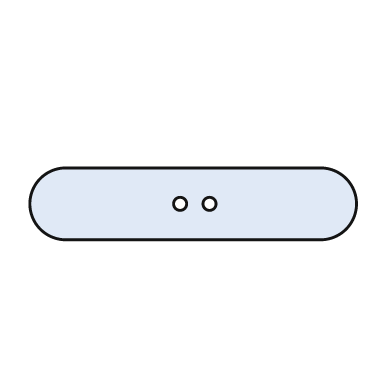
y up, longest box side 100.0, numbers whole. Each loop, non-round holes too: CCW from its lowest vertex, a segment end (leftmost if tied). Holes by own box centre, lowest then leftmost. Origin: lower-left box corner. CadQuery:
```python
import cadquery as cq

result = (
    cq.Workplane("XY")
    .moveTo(11.0, 0.0)
    .lineTo(89.0, 0.0)
    .threePointArc((100.0, 11.0), (89.0, 22.0))
    .lineTo(11.0, 22.0)
    .threePointArc((0.0, 11.0), (11.0, 0.0))
    .close()
    .moveTo(46.0, 11.0)
    .circle(2.0)
    .moveTo(55.0, 11.0)
    .circle(2.0)
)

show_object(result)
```